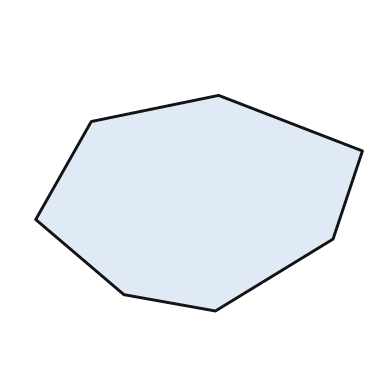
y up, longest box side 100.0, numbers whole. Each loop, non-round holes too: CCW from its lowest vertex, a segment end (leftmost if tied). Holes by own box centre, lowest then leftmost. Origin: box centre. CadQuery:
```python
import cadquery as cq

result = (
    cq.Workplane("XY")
    .moveTo(5.0, -33.0)
    .lineTo(41.0, -11.0)
    .lineTo(50.0, 16.0)
    .lineTo(6.0, 33.0)
    .lineTo(-33.0, 25.0)
    .lineTo(-50.0, -5.0)
    .lineTo(-23.0, -28.0)
    .close()
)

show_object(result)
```